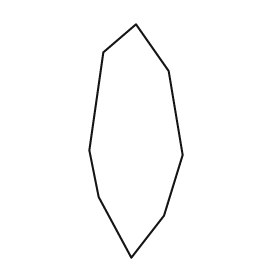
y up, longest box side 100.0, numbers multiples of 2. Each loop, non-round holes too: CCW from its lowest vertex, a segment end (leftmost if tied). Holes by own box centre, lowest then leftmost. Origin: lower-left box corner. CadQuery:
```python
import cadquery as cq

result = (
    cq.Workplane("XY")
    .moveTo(18.0, 0.0)
    .lineTo(32.0, 18.0)
    .lineTo(40.0, 44.0)
    .lineTo(34.0, 80.0)
    .lineTo(20.0, 100.0)
    .lineTo(6.0, 88.0)
    .lineTo(0.0, 46.0)
    .lineTo(4.0, 26.0)
    .close()
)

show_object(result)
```